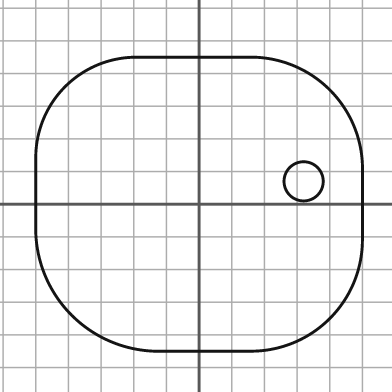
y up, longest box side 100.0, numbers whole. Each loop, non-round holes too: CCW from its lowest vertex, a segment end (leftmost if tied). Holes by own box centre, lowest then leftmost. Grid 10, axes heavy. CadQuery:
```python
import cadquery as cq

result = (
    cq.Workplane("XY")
    .moveTo(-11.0, -45.0)
    .lineTo(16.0, -45.0)
    .threePointArc((40.0, -35.0), (50.0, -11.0))
    .lineTo(50.0, 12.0)
    .threePointArc((40.0, 35.0), (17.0, 45.0))
    .lineTo(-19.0, 45.0)
    .threePointArc((-41.0, 36.0), (-50.0, 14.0))
    .lineTo(-50.0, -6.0)
    .threePointArc((-39.0, -34.0), (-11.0, -45.0))
    .close()
    .moveTo(32.0, 7.0)
    .circle(6.0)
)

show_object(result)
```